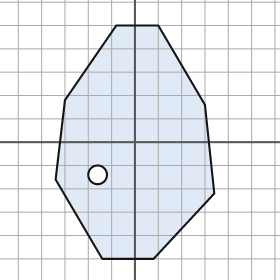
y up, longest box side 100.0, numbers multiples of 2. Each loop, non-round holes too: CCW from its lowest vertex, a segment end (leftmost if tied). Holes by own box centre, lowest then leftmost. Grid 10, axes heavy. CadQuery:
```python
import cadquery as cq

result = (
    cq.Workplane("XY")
    .moveTo(-14.0, -50.0)
    .lineTo(8.0, -50.0)
    .lineTo(34.0, -22.0)
    .lineTo(30.0, 16.0)
    .lineTo(10.0, 50.0)
    .lineTo(-8.0, 50.0)
    .lineTo(-30.0, 18.0)
    .lineTo(-34.0, -16.0)
    .close()
    .moveTo(-16.0, -14.0)
    .circle(4.0)
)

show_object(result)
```